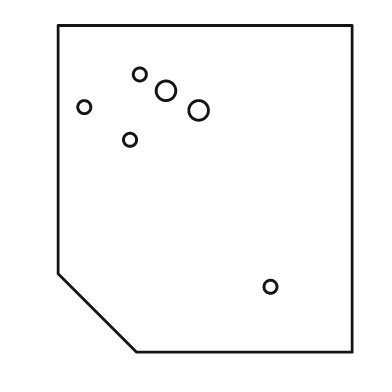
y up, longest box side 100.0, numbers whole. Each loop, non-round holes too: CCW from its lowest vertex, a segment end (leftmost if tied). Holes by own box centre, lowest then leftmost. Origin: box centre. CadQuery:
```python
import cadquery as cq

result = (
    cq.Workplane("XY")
    .moveTo(-21.0, -50.0)
    .lineTo(45.0, -50.0)
    .lineTo(45.0, 50.0)
    .lineTo(-45.0, 50.0)
    .lineTo(-45.0, -26.0)
    .close()
    .moveTo(20.0, -30.0)
    .circle(2.0)
    .moveTo(-23.0, 15.0)
    .circle(2.0)
    .moveTo(-2.0, 24.0)
    .circle(3.0)
    .moveTo(-37.0, 25.0)
    .circle(2.0)
    .moveTo(-12.0, 30.0)
    .circle(3.0)
    .moveTo(-20.0, 35.0)
    .circle(2.0)
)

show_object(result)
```